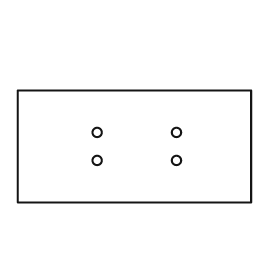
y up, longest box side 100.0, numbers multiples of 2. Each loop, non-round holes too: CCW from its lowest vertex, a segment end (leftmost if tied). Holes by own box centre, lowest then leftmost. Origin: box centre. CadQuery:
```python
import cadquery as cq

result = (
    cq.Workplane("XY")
    .moveTo(-50.0, -24.0)
    .lineTo(50.0, -24.0)
    .lineTo(50.0, 24.0)
    .lineTo(-50.0, 24.0)
    .close()
    .moveTo(-16.0, -6.0)
    .circle(2.0)
    .moveTo(18.0, -6.0)
    .circle(2.0)
    .moveTo(-16.0, 6.0)
    .circle(2.0)
    .moveTo(18.0, 6.0)
    .circle(2.0)
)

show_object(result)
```